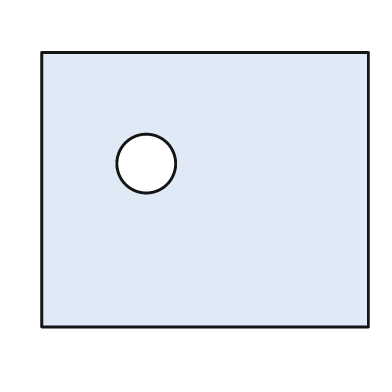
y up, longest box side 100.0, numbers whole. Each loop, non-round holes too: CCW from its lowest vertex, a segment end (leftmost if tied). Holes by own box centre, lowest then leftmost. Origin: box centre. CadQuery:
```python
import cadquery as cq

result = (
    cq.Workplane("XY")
    .moveTo(-50.0, -42.0)
    .lineTo(50.0, -42.0)
    .lineTo(50.0, 42.0)
    .lineTo(-50.0, 42.0)
    .close()
    .moveTo(-18.0, 8.0)
    .circle(9.0)
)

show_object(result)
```